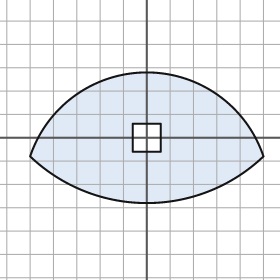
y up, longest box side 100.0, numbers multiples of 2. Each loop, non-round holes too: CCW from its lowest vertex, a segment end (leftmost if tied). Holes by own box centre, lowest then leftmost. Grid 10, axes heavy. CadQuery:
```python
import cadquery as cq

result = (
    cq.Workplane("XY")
    .moveTo(-50.0, -8.0)
    .threePointArc((0.0, -28.0), (50.0, -8.0))
    .threePointArc((0.0, 28.0), (-50.0, -8.0))
    .close()
    .moveTo(-6.0, -6.0)
    .lineTo(6.0, -6.0)
    .lineTo(6.0, 6.0)
    .lineTo(-6.0, 6.0)
    .close()
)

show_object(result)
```